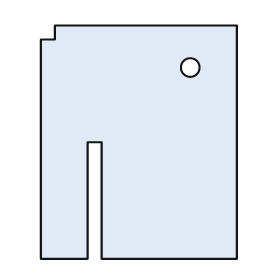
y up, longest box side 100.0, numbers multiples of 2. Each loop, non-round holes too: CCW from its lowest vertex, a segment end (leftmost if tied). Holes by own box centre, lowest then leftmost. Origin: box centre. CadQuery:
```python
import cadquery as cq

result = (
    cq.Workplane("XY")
    .moveTo(-42.0, -50.0)
    .lineTo(-22.0, -50.0)
    .lineTo(-22.0, 0.0)
    .lineTo(-16.0, 0.0)
    .lineTo(-16.0, -50.0)
    .lineTo(42.0, -50.0)
    .lineTo(42.0, 50.0)
    .lineTo(-36.0, 50.0)
    .lineTo(-36.0, 44.0)
    .lineTo(-42.0, 44.0)
    .close()
    .moveTo(22.0, 32.0)
    .circle(4.0)
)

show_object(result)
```